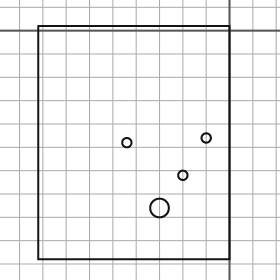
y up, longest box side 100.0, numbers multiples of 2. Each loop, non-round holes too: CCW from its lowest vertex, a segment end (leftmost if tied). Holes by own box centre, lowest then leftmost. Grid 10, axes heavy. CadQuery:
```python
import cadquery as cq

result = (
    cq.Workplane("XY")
    .moveTo(-82.0, -98.0)
    .lineTo(0.0, -98.0)
    .lineTo(0.0, 2.0)
    .lineTo(-82.0, 2.0)
    .close()
    .moveTo(-30.0, -76.0)
    .circle(4.0)
    .moveTo(-20.0, -62.0)
    .circle(2.0)
    .moveTo(-44.0, -48.0)
    .circle(2.0)
    .moveTo(-10.0, -46.0)
    .circle(2.0)
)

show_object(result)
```